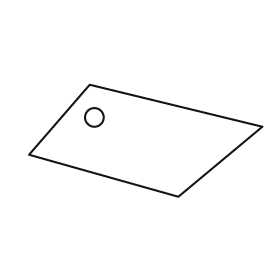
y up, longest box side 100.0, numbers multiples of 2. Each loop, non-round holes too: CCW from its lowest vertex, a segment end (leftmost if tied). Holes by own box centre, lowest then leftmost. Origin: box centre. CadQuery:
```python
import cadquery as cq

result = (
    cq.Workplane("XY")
    .moveTo(14.0, -24.0)
    .lineTo(50.0, 6.0)
    .lineTo(-24.0, 24.0)
    .lineTo(-50.0, -6.0)
    .close()
    .moveTo(-22.0, 10.0)
    .circle(4.0)
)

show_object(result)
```